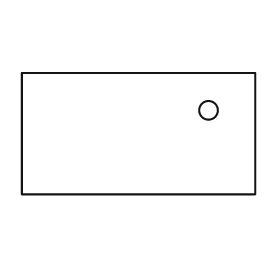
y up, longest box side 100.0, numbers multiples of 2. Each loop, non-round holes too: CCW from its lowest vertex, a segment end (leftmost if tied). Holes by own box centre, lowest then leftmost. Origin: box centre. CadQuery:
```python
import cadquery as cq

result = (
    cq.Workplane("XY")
    .moveTo(-50.0, -26.0)
    .lineTo(50.0, -26.0)
    .lineTo(50.0, 26.0)
    .lineTo(-50.0, 26.0)
    .close()
    .moveTo(30.0, 10.0)
    .circle(4.0)
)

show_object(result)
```